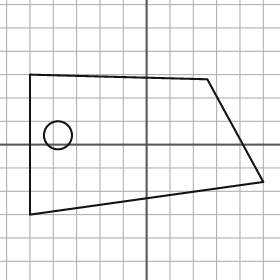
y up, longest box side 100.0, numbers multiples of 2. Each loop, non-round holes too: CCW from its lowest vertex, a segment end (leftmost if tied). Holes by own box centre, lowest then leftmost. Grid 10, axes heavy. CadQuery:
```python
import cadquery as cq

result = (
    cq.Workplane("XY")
    .moveTo(-50.0, -30.0)
    .lineTo(50.0, -16.0)
    .lineTo(26.0, 28.0)
    .lineTo(-50.0, 30.0)
    .close()
    .moveTo(-38.0, 4.0)
    .circle(6.0)
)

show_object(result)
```